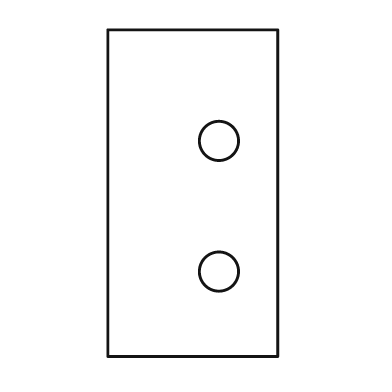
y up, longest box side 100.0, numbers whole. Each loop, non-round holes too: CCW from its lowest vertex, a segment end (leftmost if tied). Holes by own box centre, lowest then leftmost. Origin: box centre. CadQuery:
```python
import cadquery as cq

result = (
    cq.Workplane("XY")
    .moveTo(-26.0, -50.0)
    .lineTo(26.0, -50.0)
    .lineTo(26.0, 50.0)
    .lineTo(-26.0, 50.0)
    .close()
    .moveTo(8.0, -24.0)
    .circle(6.0)
    .moveTo(8.0, 16.0)
    .circle(6.0)
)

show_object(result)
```